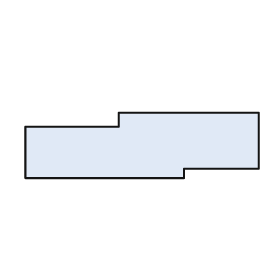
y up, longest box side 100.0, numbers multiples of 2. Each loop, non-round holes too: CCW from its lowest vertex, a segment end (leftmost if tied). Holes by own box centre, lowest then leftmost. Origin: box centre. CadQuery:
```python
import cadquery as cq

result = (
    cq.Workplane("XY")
    .moveTo(-50.0, -14.0)
    .lineTo(18.0, -14.0)
    .lineTo(18.0, -10.0)
    .lineTo(50.0, -10.0)
    .lineTo(50.0, 14.0)
    .lineTo(-10.0, 14.0)
    .lineTo(-10.0, 8.0)
    .lineTo(-50.0, 8.0)
    .close()
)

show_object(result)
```